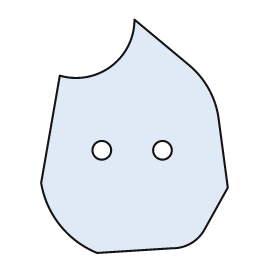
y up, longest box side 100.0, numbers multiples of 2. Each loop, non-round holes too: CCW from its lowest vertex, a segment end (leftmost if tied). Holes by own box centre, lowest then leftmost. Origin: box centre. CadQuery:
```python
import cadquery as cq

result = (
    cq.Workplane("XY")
    .moveTo(-16.0, -50.0)
    .lineTo(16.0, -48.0)
    .threePointArc((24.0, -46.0), (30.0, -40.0))
    .lineTo(40.0, -22.0)
    .lineTo(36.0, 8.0)
    .threePointArc((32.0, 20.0), (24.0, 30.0))
    .lineTo(0.0, 50.0)
    .threePointArc((-10.0, 30.0), (-32.0, 26.0))
    .lineTo(-40.0, -20.0)
    .threePointArc((-32.0, -38.0), (-16.0, -50.0))
    .close()
    .moveTo(-14.0, -6.0)
    .circle(4.0)
    .moveTo(12.0, -6.0)
    .circle(4.0)
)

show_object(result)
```